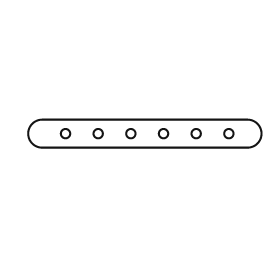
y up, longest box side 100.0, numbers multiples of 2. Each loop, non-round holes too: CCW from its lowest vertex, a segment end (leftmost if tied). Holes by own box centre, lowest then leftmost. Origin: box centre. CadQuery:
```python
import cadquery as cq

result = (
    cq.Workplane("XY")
    .moveTo(-44.0, -6.0)
    .lineTo(44.0, -6.0)
    .threePointArc((50.0, 0.0), (44.0, 6.0))
    .lineTo(-44.0, 6.0)
    .threePointArc((-50.0, 0.0), (-44.0, -6.0))
    .close()
    .moveTo(-34.0, 0.0)
    .circle(2.0)
    .moveTo(-20.0, 0.0)
    .circle(2.0)
    .moveTo(-6.0, 0.0)
    .circle(2.0)
    .moveTo(8.0, 0.0)
    .circle(2.0)
    .moveTo(22.0, 0.0)
    .circle(2.0)
    .moveTo(36.0, 0.0)
    .circle(2.0)
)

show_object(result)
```